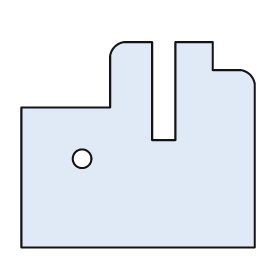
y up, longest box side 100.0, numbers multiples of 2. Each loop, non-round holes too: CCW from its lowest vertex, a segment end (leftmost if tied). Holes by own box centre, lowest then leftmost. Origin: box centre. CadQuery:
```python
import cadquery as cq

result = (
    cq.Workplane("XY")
    .moveTo(-50.0, -44.0)
    .lineTo(50.0, -44.0)
    .lineTo(50.0, 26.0)
    .threePointArc((48.0, 30.0), (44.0, 32.0))
    .lineTo(32.0, 32.0)
    .lineTo(32.0, 44.0)
    .lineTo(16.0, 44.0)
    .lineTo(16.0, 2.0)
    .lineTo(6.0, 2.0)
    .lineTo(6.0, 44.0)
    .lineTo(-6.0, 44.0)
    .threePointArc((-10.0, 42.0), (-12.0, 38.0))
    .lineTo(-12.0, 16.0)
    .lineTo(-50.0, 16.0)
    .close()
    .moveTo(-24.0, -6.0)
    .circle(4.0)
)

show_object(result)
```